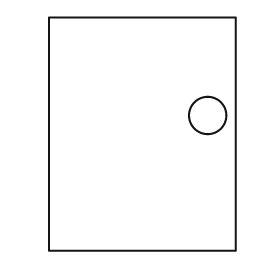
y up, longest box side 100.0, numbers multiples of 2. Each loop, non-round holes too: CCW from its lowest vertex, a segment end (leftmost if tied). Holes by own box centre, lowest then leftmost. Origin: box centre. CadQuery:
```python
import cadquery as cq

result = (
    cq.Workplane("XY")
    .moveTo(-40.0, -50.0)
    .lineTo(40.0, -50.0)
    .lineTo(40.0, 50.0)
    .lineTo(-40.0, 50.0)
    .close()
    .moveTo(28.0, 8.0)
    .circle(8.0)
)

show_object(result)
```